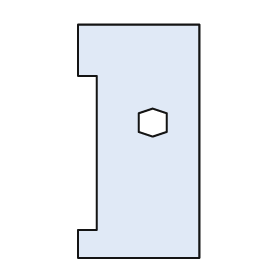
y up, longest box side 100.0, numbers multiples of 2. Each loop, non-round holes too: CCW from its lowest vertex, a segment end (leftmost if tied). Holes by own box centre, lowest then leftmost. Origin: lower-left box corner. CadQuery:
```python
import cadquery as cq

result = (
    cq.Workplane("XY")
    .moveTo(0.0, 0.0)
    .lineTo(52.0, 0.0)
    .lineTo(52.0, 100.0)
    .lineTo(0.0, 100.0)
    .lineTo(0.0, 78.0)
    .lineTo(8.0, 78.0)
    .lineTo(8.0, 12.0)
    .lineTo(0.0, 12.0)
    .close()
    .moveTo(32.0, 52.0)
    .lineTo(38.0, 54.0)
    .lineTo(38.0, 62.0)
    .lineTo(32.0, 64.0)
    .lineTo(26.0, 62.0)
    .lineTo(26.0, 54.0)
    .close()
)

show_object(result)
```